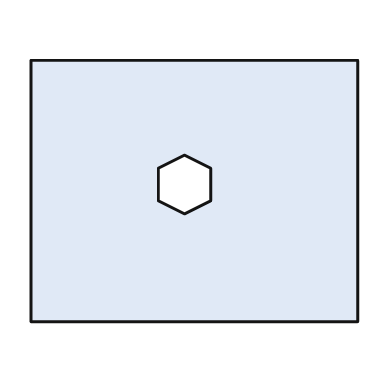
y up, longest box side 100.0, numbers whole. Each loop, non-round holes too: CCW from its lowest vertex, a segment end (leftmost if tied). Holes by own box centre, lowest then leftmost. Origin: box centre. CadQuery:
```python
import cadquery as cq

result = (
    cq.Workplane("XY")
    .moveTo(-50.0, -40.0)
    .lineTo(50.0, -40.0)
    .lineTo(50.0, 40.0)
    .lineTo(-50.0, 40.0)
    .close()
    .moveTo(-3.0, -7.0)
    .lineTo(5.0, -3.0)
    .lineTo(5.0, 7.0)
    .lineTo(-3.0, 11.0)
    .lineTo(-11.0, 7.0)
    .lineTo(-11.0, -3.0)
    .close()
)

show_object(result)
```